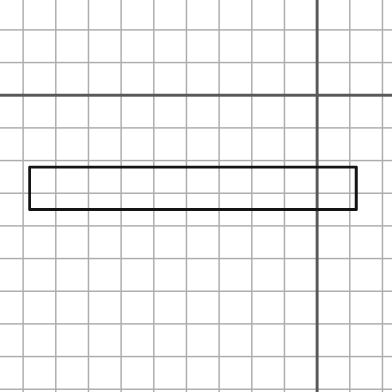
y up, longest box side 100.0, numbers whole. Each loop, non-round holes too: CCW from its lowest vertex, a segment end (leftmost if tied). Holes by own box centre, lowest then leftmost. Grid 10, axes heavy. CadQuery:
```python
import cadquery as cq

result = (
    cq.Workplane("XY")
    .moveTo(-88.0, -35.0)
    .lineTo(12.0, -35.0)
    .lineTo(12.0, -22.0)
    .lineTo(-88.0, -22.0)
    .close()
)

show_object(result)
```